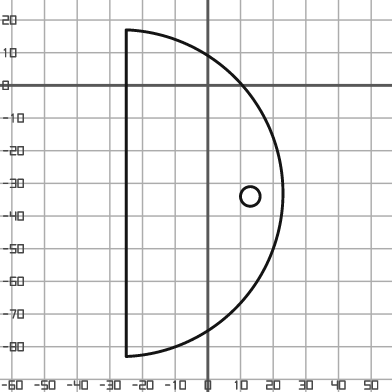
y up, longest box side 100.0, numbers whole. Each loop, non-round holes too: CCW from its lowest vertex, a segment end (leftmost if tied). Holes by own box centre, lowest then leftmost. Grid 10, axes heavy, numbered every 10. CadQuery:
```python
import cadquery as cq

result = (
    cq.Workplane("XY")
    .moveTo(-25.0, -83.0)
    .threePointArc((23.0, -33.0), (-25.0, 17.0))
    .close()
    .moveTo(13.0, -34.0)
    .circle(3.0)
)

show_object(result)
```